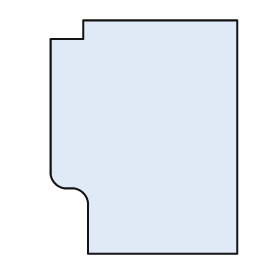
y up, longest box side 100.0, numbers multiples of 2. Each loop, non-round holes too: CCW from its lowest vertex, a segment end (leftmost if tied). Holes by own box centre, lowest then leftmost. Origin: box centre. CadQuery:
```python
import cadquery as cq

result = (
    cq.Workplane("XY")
    .moveTo(-24.0, -50.0)
    .lineTo(40.0, -50.0)
    .lineTo(40.0, 50.0)
    .lineTo(-26.0, 50.0)
    .lineTo(-26.0, 42.0)
    .lineTo(-40.0, 42.0)
    .lineTo(-40.0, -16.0)
    .threePointArc((-38.0, -20.0), (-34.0, -22.0))
    .lineTo(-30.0, -22.0)
    .threePointArc((-26.0, -24.0), (-24.0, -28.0))
    .close()
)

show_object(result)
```